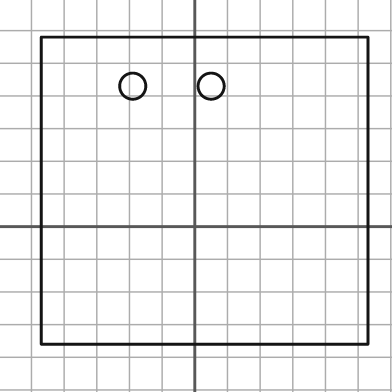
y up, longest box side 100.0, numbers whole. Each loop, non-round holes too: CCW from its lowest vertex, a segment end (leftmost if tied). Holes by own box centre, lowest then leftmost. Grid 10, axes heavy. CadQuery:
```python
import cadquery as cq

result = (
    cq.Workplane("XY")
    .moveTo(-47.0, -36.0)
    .lineTo(53.0, -36.0)
    .lineTo(53.0, 58.0)
    .lineTo(-47.0, 58.0)
    .close()
    .moveTo(-19.0, 43.0)
    .circle(4.0)
    .moveTo(5.0, 43.0)
    .circle(4.0)
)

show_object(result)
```